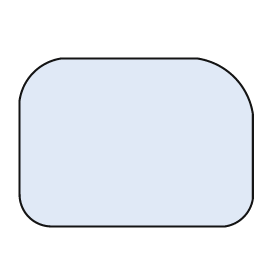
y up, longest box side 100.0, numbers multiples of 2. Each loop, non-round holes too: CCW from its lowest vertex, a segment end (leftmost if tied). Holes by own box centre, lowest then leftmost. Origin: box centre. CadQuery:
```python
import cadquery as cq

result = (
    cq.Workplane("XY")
    .moveTo(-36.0, -36.0)
    .lineTo(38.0, -36.0)
    .threePointArc((46.0, -32.0), (50.0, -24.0))
    .lineTo(50.0, 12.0)
    .threePointArc((42.0, 28.0), (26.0, 36.0))
    .lineTo(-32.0, 36.0)
    .threePointArc((-44.0, 30.0), (-50.0, 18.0))
    .lineTo(-50.0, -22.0)
    .threePointArc((-46.0, -32.0), (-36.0, -36.0))
    .close()
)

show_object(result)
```